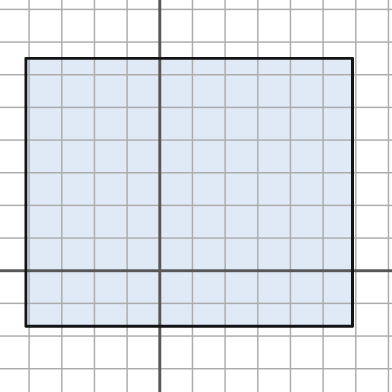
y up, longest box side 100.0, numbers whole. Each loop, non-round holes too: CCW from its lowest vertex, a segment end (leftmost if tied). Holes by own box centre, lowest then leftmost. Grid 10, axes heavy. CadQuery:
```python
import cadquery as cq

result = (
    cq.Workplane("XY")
    .moveTo(-41.0, -17.0)
    .lineTo(59.0, -17.0)
    .lineTo(59.0, 65.0)
    .lineTo(-41.0, 65.0)
    .close()
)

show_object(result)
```